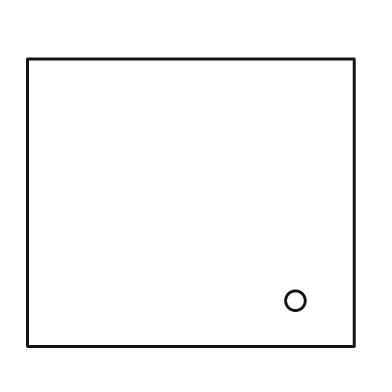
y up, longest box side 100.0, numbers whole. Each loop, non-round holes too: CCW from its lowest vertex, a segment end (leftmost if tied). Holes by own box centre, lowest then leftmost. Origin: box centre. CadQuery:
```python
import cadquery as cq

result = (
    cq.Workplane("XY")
    .moveTo(-50.0, -44.0)
    .lineTo(50.0, -44.0)
    .lineTo(50.0, 44.0)
    .lineTo(-50.0, 44.0)
    .close()
    .moveTo(32.0, -30.0)
    .circle(3.0)
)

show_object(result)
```